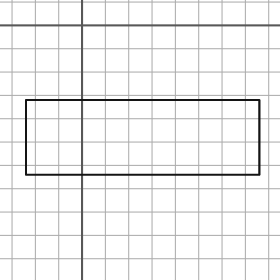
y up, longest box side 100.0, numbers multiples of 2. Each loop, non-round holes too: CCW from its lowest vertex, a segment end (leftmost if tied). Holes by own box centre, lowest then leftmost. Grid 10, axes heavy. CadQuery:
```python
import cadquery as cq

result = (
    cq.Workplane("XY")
    .moveTo(-24.0, -64.0)
    .lineTo(76.0, -64.0)
    .lineTo(76.0, -32.0)
    .lineTo(-24.0, -32.0)
    .close()
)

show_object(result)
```